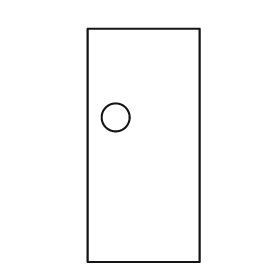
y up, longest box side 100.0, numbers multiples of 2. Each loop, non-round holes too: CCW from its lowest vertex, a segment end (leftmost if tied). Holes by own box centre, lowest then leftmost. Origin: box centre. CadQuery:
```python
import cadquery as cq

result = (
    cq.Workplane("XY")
    .moveTo(-24.0, -50.0)
    .lineTo(24.0, -50.0)
    .lineTo(24.0, 50.0)
    .lineTo(-24.0, 50.0)
    .close()
    .moveTo(-12.0, 12.0)
    .circle(6.0)
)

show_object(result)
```